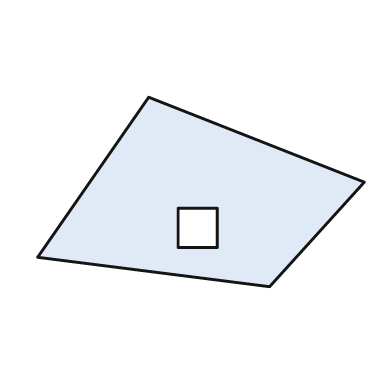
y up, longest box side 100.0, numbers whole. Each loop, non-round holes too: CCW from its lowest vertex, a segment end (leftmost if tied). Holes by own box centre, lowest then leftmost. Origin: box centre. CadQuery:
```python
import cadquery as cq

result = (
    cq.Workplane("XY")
    .moveTo(21.0, -29.0)
    .lineTo(50.0, 3.0)
    .lineTo(-16.0, 29.0)
    .lineTo(-50.0, -20.0)
    .close()
    .moveTo(-7.0, -17.0)
    .lineTo(5.0, -17.0)
    .lineTo(5.0, -5.0)
    .lineTo(-7.0, -5.0)
    .close()
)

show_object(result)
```